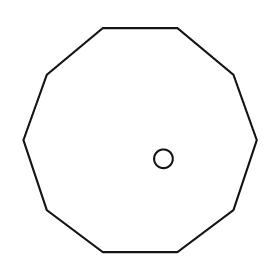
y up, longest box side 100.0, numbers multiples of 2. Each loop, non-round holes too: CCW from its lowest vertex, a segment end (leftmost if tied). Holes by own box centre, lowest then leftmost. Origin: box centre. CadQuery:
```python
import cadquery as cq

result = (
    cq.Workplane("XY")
    .moveTo(-16.0, -48.0)
    .lineTo(16.0, -48.0)
    .lineTo(40.0, -30.0)
    .lineTo(50.0, 0.0)
    .lineTo(40.0, 28.0)
    .lineTo(16.0, 48.0)
    .lineTo(-16.0, 48.0)
    .lineTo(-40.0, 28.0)
    .lineTo(-50.0, 0.0)
    .lineTo(-40.0, -30.0)
    .close()
    .moveTo(10.0, -8.0)
    .circle(4.0)
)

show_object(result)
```